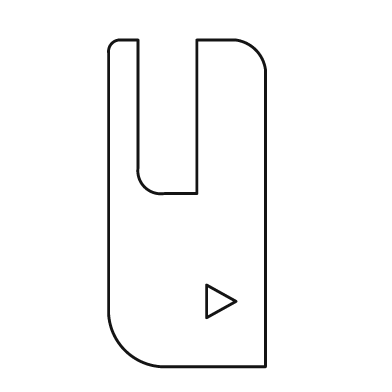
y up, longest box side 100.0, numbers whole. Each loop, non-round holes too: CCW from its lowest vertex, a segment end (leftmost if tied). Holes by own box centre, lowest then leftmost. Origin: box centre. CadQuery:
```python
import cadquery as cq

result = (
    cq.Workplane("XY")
    .moveTo(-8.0, -50.0)
    .lineTo(24.0, -50.0)
    .lineTo(24.0, 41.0)
    .threePointArc((21.0, 47.0), (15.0, 50.0))
    .lineTo(3.0, 50.0)
    .lineTo(3.0, 3.0)
    .lineTo(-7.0, 3.0)
    .threePointArc((-13.0, 5.0), (-15.0, 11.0))
    .lineTo(-15.0, 50.0)
    .lineTo(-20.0, 50.0)
    .threePointArc((-23.0, 49.0), (-24.0, 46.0))
    .lineTo(-24.0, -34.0)
    .threePointArc((-19.0, -45.0), (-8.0, -50.0))
    .close()
    .moveTo(6.0, -35.0)
    .lineTo(15.0, -30.0)
    .lineTo(6.0, -25.0)
    .close()
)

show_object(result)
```